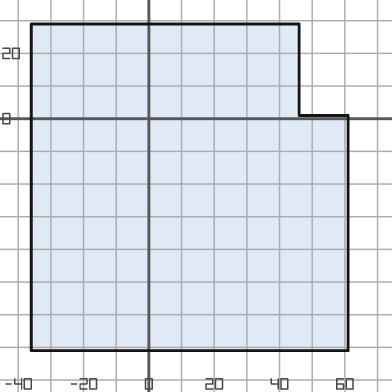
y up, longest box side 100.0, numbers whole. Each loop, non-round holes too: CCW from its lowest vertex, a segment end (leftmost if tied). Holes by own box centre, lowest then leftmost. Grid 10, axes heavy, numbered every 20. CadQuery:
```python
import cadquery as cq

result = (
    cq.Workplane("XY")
    .moveTo(-36.0, -71.0)
    .lineTo(61.0, -71.0)
    .lineTo(61.0, 1.0)
    .lineTo(46.0, 1.0)
    .lineTo(46.0, 29.0)
    .lineTo(-36.0, 29.0)
    .close()
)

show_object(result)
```